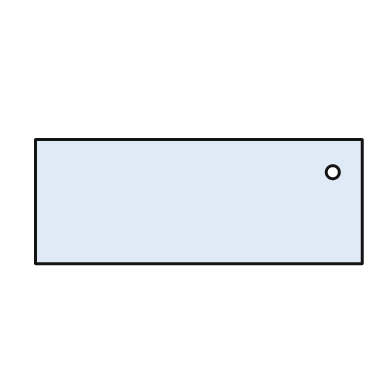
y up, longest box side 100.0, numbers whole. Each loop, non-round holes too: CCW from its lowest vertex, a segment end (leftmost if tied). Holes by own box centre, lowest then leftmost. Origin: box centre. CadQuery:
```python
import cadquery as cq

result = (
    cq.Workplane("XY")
    .moveTo(-50.0, -19.0)
    .lineTo(50.0, -19.0)
    .lineTo(50.0, 19.0)
    .lineTo(-50.0, 19.0)
    .close()
    .moveTo(41.0, 9.0)
    .circle(2.0)
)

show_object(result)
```